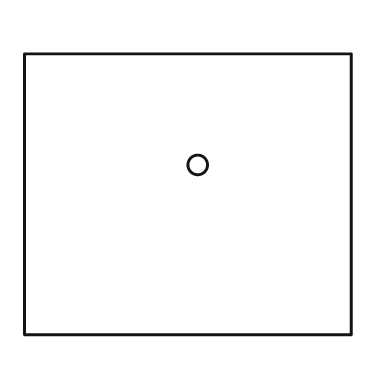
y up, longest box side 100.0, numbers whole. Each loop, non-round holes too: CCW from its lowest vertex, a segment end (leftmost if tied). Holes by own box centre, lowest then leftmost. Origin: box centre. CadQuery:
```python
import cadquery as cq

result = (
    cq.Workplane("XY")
    .moveTo(-50.0, -43.0)
    .lineTo(50.0, -43.0)
    .lineTo(50.0, 43.0)
    .lineTo(-50.0, 43.0)
    .close()
    .moveTo(3.0, 9.0)
    .circle(3.0)
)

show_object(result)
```